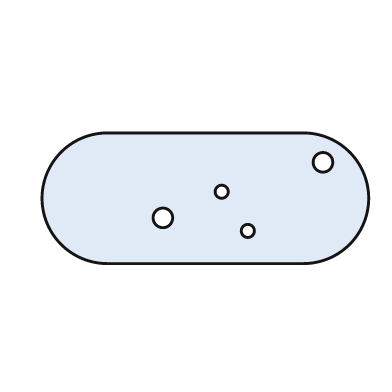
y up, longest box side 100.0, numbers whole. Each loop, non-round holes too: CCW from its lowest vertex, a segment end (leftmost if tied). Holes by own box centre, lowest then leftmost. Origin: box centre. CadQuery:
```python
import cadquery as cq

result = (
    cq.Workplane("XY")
    .moveTo(-30.0, -20.0)
    .lineTo(30.0, -20.0)
    .threePointArc((50.0, 0.0), (30.0, 20.0))
    .lineTo(-30.0, 20.0)
    .threePointArc((-50.0, 0.0), (-30.0, -20.0))
    .close()
    .moveTo(13.0, -10.0)
    .circle(2.0)
    .moveTo(-13.0, -6.0)
    .circle(3.0)
    .moveTo(5.0, 2.0)
    .circle(2.0)
    .moveTo(36.0, 11.0)
    .circle(3.0)
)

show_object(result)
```